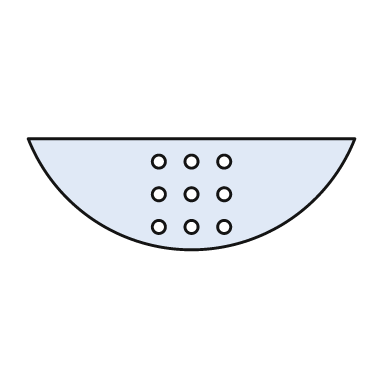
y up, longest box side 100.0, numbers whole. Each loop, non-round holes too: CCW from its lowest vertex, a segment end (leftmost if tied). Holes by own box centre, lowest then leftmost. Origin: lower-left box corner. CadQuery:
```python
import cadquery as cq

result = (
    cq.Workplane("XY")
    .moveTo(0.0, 34.0)
    .threePointArc((50.0, 0.0), (100.0, 34.0))
    .close()
    .moveTo(40.0, 7.0)
    .circle(2.0)
    .moveTo(50.0, 7.0)
    .circle(2.0)
    .moveTo(60.0, 7.0)
    .circle(2.0)
    .moveTo(40.0, 17.0)
    .circle(2.0)
    .moveTo(50.0, 17.0)
    .circle(2.0)
    .moveTo(60.0, 17.0)
    .circle(2.0)
    .moveTo(40.0, 27.0)
    .circle(2.0)
    .moveTo(50.0, 27.0)
    .circle(2.0)
    .moveTo(60.0, 27.0)
    .circle(2.0)
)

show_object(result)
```